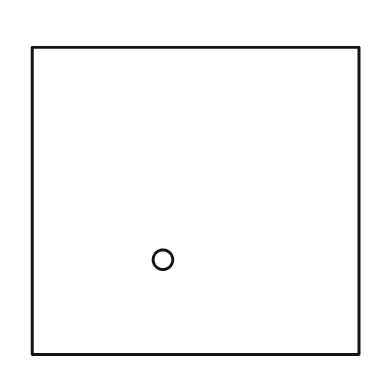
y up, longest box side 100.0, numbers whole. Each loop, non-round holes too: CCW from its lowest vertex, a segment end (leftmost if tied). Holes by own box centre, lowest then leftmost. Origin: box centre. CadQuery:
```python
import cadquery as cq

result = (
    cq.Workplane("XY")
    .moveTo(-50.0, -47.0)
    .lineTo(50.0, -47.0)
    .lineTo(50.0, 47.0)
    .lineTo(-50.0, 47.0)
    .close()
    .moveTo(-10.0, -18.0)
    .circle(3.0)
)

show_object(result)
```